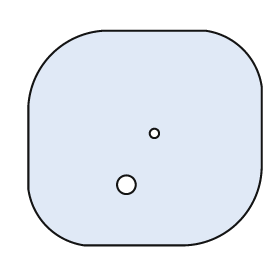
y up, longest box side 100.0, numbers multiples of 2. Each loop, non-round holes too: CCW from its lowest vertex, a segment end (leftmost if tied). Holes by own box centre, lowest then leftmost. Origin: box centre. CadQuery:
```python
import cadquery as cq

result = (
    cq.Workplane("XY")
    .moveTo(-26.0, -46.0)
    .lineTo(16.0, -46.0)
    .threePointArc((40.0, -36.0), (50.0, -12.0))
    .lineTo(50.0, 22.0)
    .threePointArc((42.0, 38.0), (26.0, 46.0))
    .lineTo(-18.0, 46.0)
    .threePointArc((-40.0, 36.0), (-50.0, 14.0))
    .lineTo(-50.0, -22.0)
    .threePointArc((-42.0, -38.0), (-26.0, -46.0))
    .close()
    .moveTo(-8.0, -20.0)
    .circle(4.0)
    .moveTo(4.0, 2.0)
    .circle(2.0)
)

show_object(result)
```